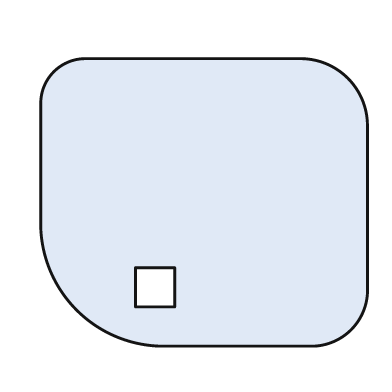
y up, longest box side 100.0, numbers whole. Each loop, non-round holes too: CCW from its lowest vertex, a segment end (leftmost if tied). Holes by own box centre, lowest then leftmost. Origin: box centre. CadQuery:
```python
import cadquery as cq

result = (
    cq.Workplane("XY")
    .moveTo(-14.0, -44.0)
    .lineTo(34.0, -44.0)
    .threePointArc((45.0, -39.0), (50.0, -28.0))
    .lineTo(50.0, 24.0)
    .threePointArc((44.0, 38.0), (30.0, 44.0))
    .lineTo(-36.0, 44.0)
    .threePointArc((-46.0, 40.0), (-50.0, 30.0))
    .lineTo(-50.0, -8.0)
    .threePointArc((-39.0, -33.0), (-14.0, -44.0))
    .close()
    .moveTo(-21.0, -32.0)
    .lineTo(-9.0, -32.0)
    .lineTo(-9.0, -20.0)
    .lineTo(-21.0, -20.0)
    .close()
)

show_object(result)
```